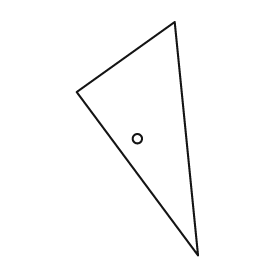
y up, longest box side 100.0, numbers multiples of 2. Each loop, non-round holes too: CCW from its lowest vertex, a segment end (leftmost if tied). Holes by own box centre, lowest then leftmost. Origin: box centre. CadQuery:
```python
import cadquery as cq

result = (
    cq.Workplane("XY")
    .moveTo(26.0, -50.0)
    .lineTo(16.0, 50.0)
    .lineTo(-26.0, 20.0)
    .close()
    .moveTo(0.0, 0.0)
    .circle(2.0)
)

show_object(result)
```